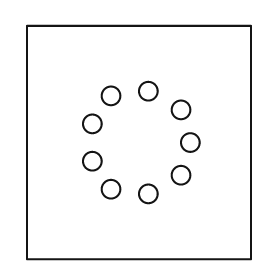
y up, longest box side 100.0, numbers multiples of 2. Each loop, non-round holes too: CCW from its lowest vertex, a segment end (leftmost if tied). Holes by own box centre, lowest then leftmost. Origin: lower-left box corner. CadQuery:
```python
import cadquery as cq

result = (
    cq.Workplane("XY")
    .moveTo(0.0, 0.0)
    .lineTo(96.0, 0.0)
    .lineTo(96.0, 100.0)
    .lineTo(0.0, 100.0)
    .close()
    .moveTo(52.0, 28.0)
    .circle(4.0)
    .moveTo(36.0, 30.0)
    .circle(4.0)
    .moveTo(66.0, 36.0)
    .circle(4.0)
    .moveTo(28.0, 42.0)
    .circle(4.0)
    .moveTo(70.0, 50.0)
    .circle(4.0)
    .moveTo(28.0, 58.0)
    .circle(4.0)
    .moveTo(66.0, 64.0)
    .circle(4.0)
    .moveTo(36.0, 70.0)
    .circle(4.0)
    .moveTo(52.0, 72.0)
    .circle(4.0)
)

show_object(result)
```